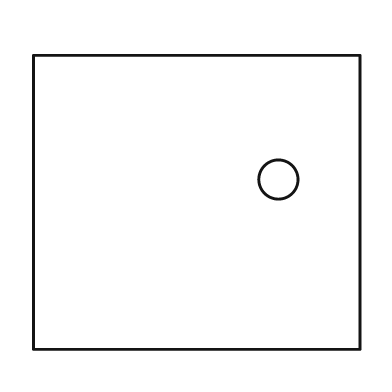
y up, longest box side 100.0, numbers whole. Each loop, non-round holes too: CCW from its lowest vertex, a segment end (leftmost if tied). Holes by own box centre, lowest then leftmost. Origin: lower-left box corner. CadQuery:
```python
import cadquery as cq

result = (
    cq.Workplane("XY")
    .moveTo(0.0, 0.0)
    .lineTo(100.0, 0.0)
    .lineTo(100.0, 90.0)
    .lineTo(0.0, 90.0)
    .close()
    .moveTo(75.0, 52.0)
    .circle(6.0)
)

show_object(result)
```